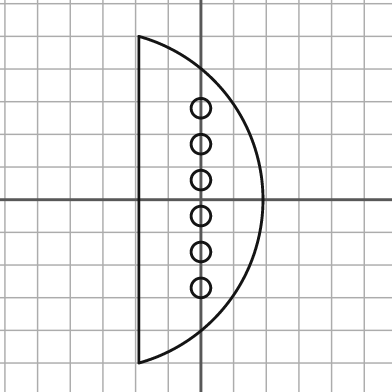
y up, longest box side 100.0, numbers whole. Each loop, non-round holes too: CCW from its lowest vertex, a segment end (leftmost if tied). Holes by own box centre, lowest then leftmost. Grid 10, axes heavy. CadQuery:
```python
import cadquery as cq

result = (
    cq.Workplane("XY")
    .moveTo(-19.0, -50.0)
    .threePointArc((19.0, 0.0), (-19.0, 50.0))
    .close()
    .moveTo(0.0, -27.0)
    .circle(3.0)
    .moveTo(0.0, -16.0)
    .circle(3.0)
    .moveTo(0.0, -5.0)
    .circle(3.0)
    .moveTo(0.0, 6.0)
    .circle(3.0)
    .moveTo(0.0, 17.0)
    .circle(3.0)
    .moveTo(0.0, 28.0)
    .circle(3.0)
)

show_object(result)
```